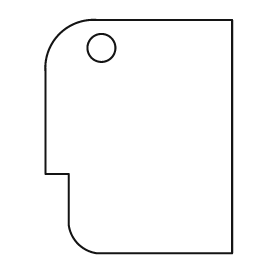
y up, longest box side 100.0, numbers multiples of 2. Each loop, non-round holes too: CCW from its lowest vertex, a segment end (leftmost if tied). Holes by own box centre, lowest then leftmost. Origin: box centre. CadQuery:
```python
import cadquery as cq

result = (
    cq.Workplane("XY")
    .moveTo(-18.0, -50.0)
    .lineTo(40.0, -50.0)
    .lineTo(40.0, 50.0)
    .lineTo(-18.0, 50.0)
    .threePointArc((-34.0, 44.0), (-40.0, 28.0))
    .lineTo(-40.0, -16.0)
    .lineTo(-30.0, -16.0)
    .lineTo(-30.0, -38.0)
    .threePointArc((-26.0, -46.0), (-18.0, -50.0))
    .close()
    .moveTo(-16.0, 38.0)
    .circle(6.0)
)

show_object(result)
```